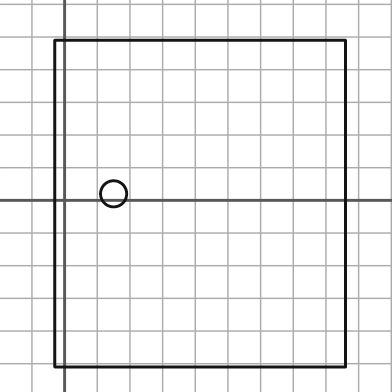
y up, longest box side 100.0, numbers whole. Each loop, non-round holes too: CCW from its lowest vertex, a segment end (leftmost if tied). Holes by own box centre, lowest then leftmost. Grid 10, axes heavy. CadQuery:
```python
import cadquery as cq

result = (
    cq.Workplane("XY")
    .moveTo(-3.0, -51.0)
    .lineTo(86.0, -51.0)
    .lineTo(86.0, 49.0)
    .lineTo(-3.0, 49.0)
    .close()
    .moveTo(15.0, 2.0)
    .circle(4.0)
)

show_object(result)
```